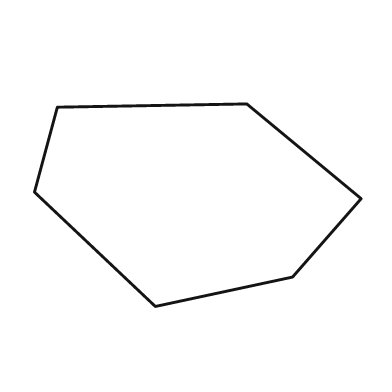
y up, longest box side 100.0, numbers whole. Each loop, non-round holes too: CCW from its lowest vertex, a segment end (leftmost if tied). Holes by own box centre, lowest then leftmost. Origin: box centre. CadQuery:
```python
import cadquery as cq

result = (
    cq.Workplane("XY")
    .moveTo(-13.0, -31.0)
    .lineTo(29.0, -22.0)
    .lineTo(50.0, 2.0)
    .lineTo(15.0, 31.0)
    .lineTo(-43.0, 30.0)
    .lineTo(-50.0, 4.0)
    .close()
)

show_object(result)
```